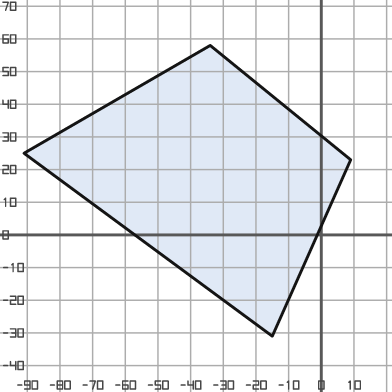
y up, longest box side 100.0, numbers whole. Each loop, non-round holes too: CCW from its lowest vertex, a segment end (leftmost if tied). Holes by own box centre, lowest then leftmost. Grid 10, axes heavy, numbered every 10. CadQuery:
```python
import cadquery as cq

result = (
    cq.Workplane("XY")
    .moveTo(-15.0, -31.0)
    .lineTo(9.0, 23.0)
    .lineTo(-34.0, 58.0)
    .lineTo(-91.0, 25.0)
    .close()
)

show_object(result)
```